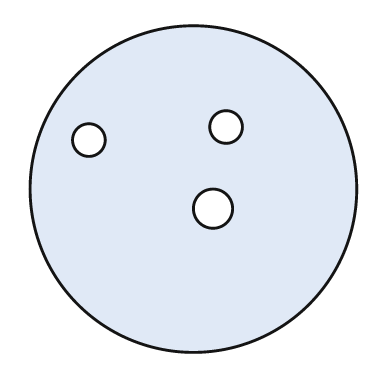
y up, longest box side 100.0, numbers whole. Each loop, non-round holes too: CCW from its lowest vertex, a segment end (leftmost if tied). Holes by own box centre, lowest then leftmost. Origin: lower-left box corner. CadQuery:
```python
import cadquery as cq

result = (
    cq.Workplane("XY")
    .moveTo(50.0, 50.0)
    .circle(50.0)
    .moveTo(56.0, 44.0)
    .circle(6.0)
    .moveTo(18.0, 65.0)
    .circle(5.0)
    .moveTo(60.0, 69.0)
    .circle(5.0)
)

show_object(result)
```